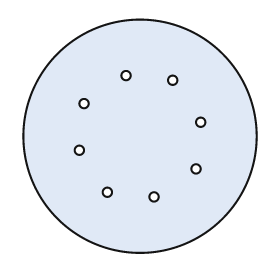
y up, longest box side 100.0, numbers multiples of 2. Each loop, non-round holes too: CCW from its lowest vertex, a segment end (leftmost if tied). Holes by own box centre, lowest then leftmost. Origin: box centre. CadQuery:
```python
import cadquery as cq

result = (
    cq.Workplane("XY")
    .moveTo(0.0, 0.0)
    .circle(50.0)
    .moveTo(6.0, -26.0)
    .circle(2.0)
    .moveTo(-14.0, -24.0)
    .circle(2.0)
    .moveTo(24.0, -14.0)
    .circle(2.0)
    .moveTo(-26.0, -6.0)
    .circle(2.0)
    .moveTo(26.0, 6.0)
    .circle(2.0)
    .moveTo(-24.0, 14.0)
    .circle(2.0)
    .moveTo(14.0, 24.0)
    .circle(2.0)
    .moveTo(-6.0, 26.0)
    .circle(2.0)
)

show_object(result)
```